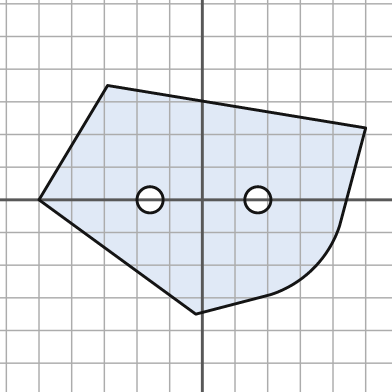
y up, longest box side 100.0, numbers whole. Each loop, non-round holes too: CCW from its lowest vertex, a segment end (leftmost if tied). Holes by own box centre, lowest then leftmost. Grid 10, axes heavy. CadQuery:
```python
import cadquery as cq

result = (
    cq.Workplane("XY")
    .moveTo(-2.0, -35.0)
    .lineTo(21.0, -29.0)
    .threePointArc((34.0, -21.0), (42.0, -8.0))
    .lineTo(50.0, 22.0)
    .lineTo(-29.0, 35.0)
    .lineTo(-50.0, 0.0)
    .close()
    .moveTo(-16.0, 0.0)
    .circle(4.0)
    .moveTo(17.0, 0.0)
    .circle(4.0)
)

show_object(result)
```